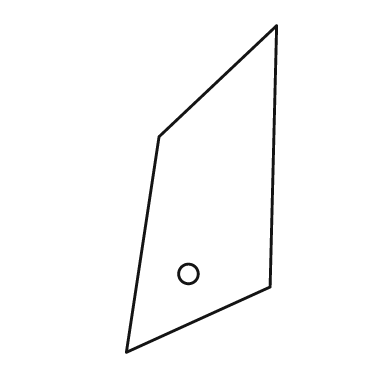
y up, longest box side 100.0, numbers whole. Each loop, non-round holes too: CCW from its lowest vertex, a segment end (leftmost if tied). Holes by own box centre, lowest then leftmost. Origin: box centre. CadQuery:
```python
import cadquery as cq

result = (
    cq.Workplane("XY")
    .moveTo(-23.0, -50.0)
    .lineTo(21.0, -30.0)
    .lineTo(23.0, 50.0)
    .lineTo(-13.0, 16.0)
    .close()
    .moveTo(-4.0, -26.0)
    .circle(3.0)
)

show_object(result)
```